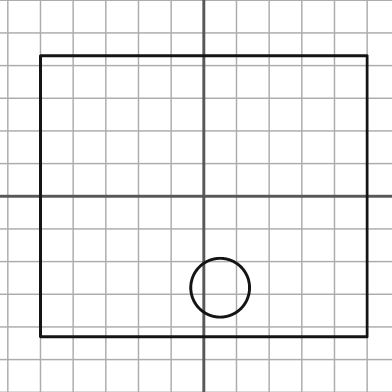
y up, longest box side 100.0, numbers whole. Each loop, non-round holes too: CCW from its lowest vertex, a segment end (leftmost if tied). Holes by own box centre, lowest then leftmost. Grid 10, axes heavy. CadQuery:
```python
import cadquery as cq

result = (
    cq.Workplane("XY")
    .moveTo(-50.0, -43.0)
    .lineTo(50.0, -43.0)
    .lineTo(50.0, 43.0)
    .lineTo(-50.0, 43.0)
    .close()
    .moveTo(5.0, -28.0)
    .circle(9.0)
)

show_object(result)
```